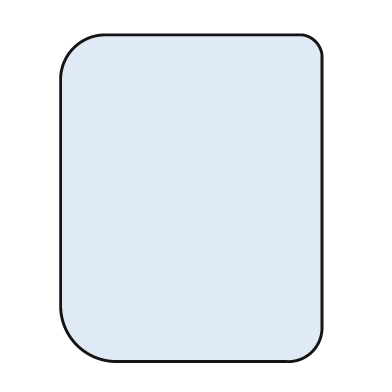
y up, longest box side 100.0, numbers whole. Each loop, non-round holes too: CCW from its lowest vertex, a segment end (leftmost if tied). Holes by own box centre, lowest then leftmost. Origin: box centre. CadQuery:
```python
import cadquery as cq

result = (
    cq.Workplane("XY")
    .moveTo(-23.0, -50.0)
    .lineTo(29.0, -50.0)
    .threePointArc((37.0, -47.0), (40.0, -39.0))
    .lineTo(40.0, 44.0)
    .threePointArc((38.0, 48.0), (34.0, 50.0))
    .lineTo(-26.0, 50.0)
    .threePointArc((-36.0, 46.0), (-40.0, 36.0))
    .lineTo(-40.0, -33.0)
    .threePointArc((-35.0, -45.0), (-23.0, -50.0))
    .close()
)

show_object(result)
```